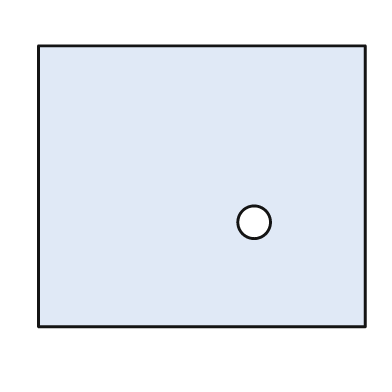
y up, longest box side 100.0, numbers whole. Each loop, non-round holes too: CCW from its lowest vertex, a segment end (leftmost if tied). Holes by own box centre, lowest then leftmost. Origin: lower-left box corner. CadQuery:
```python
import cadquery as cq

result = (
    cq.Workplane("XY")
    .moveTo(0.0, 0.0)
    .lineTo(100.0, 0.0)
    .lineTo(100.0, 86.0)
    .lineTo(0.0, 86.0)
    .close()
    .moveTo(66.0, 32.0)
    .circle(5.0)
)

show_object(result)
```